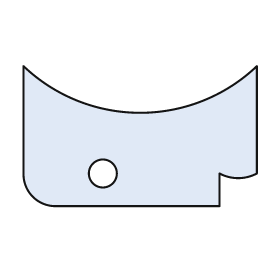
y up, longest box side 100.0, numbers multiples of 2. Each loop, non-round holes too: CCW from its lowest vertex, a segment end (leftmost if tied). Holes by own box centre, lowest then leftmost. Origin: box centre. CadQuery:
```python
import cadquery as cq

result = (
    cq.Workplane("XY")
    .moveTo(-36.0, -30.0)
    .lineTo(34.0, -30.0)
    .lineTo(34.0, -16.0)
    .threePointArc((42.0, -18.0), (50.0, -16.0))
    .lineTo(50.0, 30.0)
    .threePointArc((0.0, 10.0), (-50.0, 30.0))
    .lineTo(-50.0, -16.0)
    .threePointArc((-46.0, -26.0), (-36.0, -30.0))
    .close()
    .moveTo(-16.0, -16.0)
    .circle(6.0)
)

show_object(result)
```